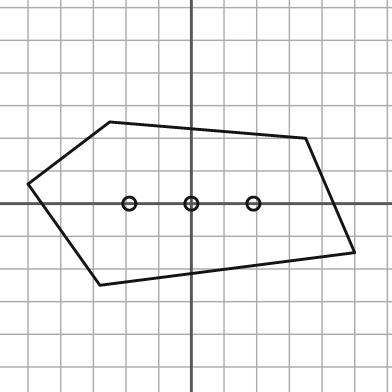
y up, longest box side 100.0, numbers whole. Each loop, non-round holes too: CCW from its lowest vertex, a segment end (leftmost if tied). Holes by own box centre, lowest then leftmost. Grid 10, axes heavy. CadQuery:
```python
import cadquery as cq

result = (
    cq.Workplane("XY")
    .moveTo(-28.0, -25.0)
    .lineTo(50.0, -15.0)
    .lineTo(35.0, 20.0)
    .lineTo(-25.0, 25.0)
    .lineTo(-50.0, 6.0)
    .close()
    .moveTo(-19.0, 0.0)
    .circle(2.0)
    .moveTo(0.0, 0.0)
    .circle(2.0)
    .moveTo(19.0, 0.0)
    .circle(2.0)
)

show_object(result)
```